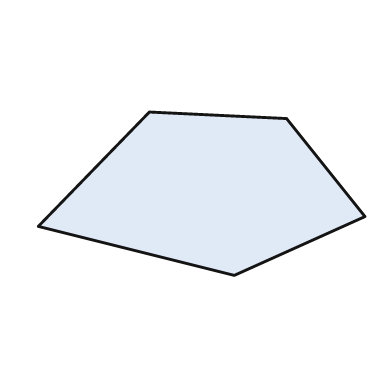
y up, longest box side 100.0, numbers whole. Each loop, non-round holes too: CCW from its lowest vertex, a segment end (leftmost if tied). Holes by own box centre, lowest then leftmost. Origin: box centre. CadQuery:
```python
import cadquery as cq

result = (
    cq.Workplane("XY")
    .moveTo(10.0, -25.0)
    .lineTo(50.0, -7.0)
    .lineTo(26.0, 23.0)
    .lineTo(-16.0, 25.0)
    .lineTo(-50.0, -10.0)
    .close()
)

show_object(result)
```